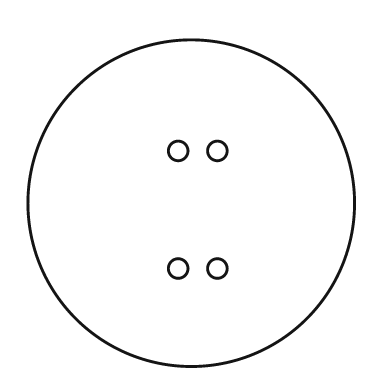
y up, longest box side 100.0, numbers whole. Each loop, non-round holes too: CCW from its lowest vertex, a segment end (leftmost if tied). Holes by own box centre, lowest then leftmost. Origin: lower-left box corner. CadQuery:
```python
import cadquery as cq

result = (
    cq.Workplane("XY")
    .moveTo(50.0, 50.0)
    .circle(50.0)
    .moveTo(46.0, 30.0)
    .circle(3.0)
    .moveTo(58.0, 30.0)
    .circle(3.0)
    .moveTo(46.0, 66.0)
    .circle(3.0)
    .moveTo(58.0, 66.0)
    .circle(3.0)
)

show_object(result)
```